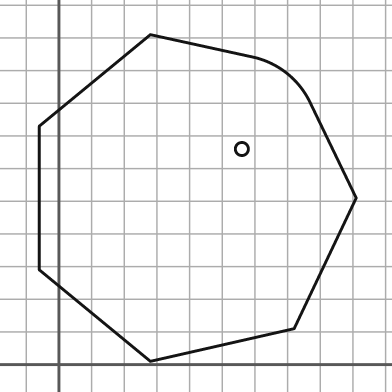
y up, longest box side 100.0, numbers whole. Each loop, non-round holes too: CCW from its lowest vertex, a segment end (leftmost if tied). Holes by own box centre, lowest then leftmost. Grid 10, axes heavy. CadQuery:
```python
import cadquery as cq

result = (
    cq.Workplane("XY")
    .moveTo(28.0, 1.0)
    .lineTo(72.0, 11.0)
    .lineTo(91.0, 51.0)
    .lineTo(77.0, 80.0)
    .threePointArc((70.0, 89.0), (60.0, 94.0))
    .lineTo(28.0, 101.0)
    .lineTo(-6.0, 73.0)
    .lineTo(-6.0, 29.0)
    .close()
    .moveTo(56.0, 66.0)
    .circle(2.0)
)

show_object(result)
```